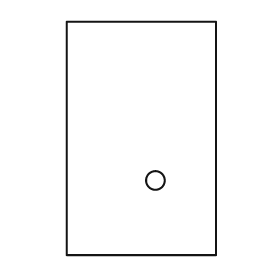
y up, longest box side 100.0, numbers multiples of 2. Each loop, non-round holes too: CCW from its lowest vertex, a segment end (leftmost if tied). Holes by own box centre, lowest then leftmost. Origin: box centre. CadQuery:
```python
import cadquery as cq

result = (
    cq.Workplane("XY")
    .moveTo(-32.0, -50.0)
    .lineTo(32.0, -50.0)
    .lineTo(32.0, 50.0)
    .lineTo(-32.0, 50.0)
    .close()
    .moveTo(6.0, -18.0)
    .circle(4.0)
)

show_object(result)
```